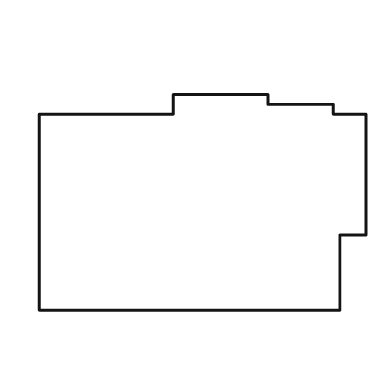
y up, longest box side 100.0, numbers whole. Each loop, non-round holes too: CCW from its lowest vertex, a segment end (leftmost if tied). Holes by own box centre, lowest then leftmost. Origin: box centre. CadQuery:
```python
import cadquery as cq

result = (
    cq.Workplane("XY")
    .moveTo(-50.0, -33.0)
    .lineTo(42.0, -33.0)
    .lineTo(42.0, -10.0)
    .lineTo(50.0, -10.0)
    .lineTo(50.0, 27.0)
    .lineTo(40.0, 27.0)
    .lineTo(40.0, 30.0)
    .lineTo(20.0, 30.0)
    .lineTo(20.0, 33.0)
    .lineTo(-9.0, 33.0)
    .lineTo(-9.0, 27.0)
    .lineTo(-50.0, 27.0)
    .close()
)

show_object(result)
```